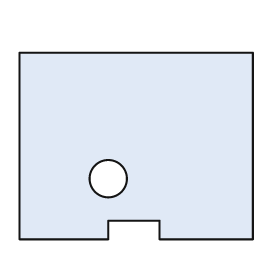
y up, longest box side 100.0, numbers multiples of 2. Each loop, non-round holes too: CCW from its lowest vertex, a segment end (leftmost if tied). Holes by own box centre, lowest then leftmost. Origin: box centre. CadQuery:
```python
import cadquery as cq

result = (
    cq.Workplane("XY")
    .moveTo(-50.0, -40.0)
    .lineTo(-12.0, -40.0)
    .lineTo(-12.0, -32.0)
    .lineTo(10.0, -32.0)
    .lineTo(10.0, -40.0)
    .lineTo(50.0, -40.0)
    .lineTo(50.0, 40.0)
    .lineTo(-50.0, 40.0)
    .close()
    .moveTo(-12.0, -14.0)
    .circle(8.0)
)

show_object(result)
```